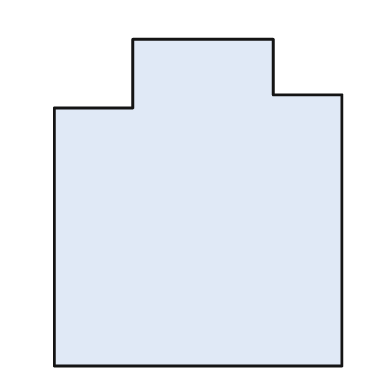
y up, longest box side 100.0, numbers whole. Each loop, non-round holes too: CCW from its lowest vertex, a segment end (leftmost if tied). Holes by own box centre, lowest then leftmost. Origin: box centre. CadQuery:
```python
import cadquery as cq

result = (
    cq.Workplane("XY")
    .moveTo(-44.0, -50.0)
    .lineTo(44.0, -50.0)
    .lineTo(44.0, 33.0)
    .lineTo(23.0, 33.0)
    .lineTo(23.0, 50.0)
    .lineTo(-20.0, 50.0)
    .lineTo(-20.0, 29.0)
    .lineTo(-44.0, 29.0)
    .close()
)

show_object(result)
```